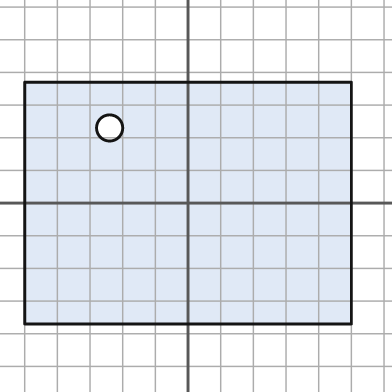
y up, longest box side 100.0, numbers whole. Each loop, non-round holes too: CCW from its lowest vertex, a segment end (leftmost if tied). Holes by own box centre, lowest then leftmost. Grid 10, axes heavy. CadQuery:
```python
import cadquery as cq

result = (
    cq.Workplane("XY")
    .moveTo(-50.0, -37.0)
    .lineTo(50.0, -37.0)
    .lineTo(50.0, 37.0)
    .lineTo(-50.0, 37.0)
    .close()
    .moveTo(-24.0, 23.0)
    .circle(4.0)
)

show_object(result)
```